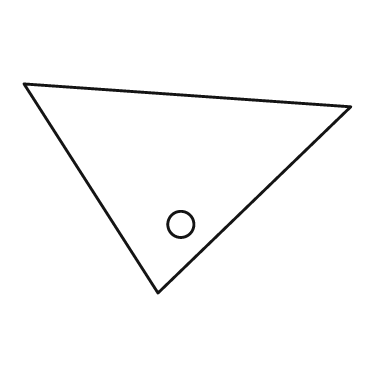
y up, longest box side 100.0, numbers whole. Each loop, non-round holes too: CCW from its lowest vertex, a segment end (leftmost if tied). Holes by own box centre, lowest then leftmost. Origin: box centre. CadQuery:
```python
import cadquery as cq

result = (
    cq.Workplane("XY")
    .moveTo(-9.0, -32.0)
    .lineTo(50.0, 25.0)
    .lineTo(-50.0, 32.0)
    .close()
    .moveTo(-2.0, -11.0)
    .circle(4.0)
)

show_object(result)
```